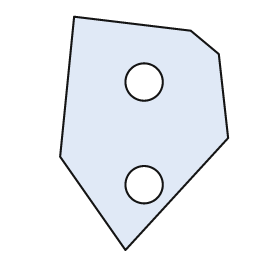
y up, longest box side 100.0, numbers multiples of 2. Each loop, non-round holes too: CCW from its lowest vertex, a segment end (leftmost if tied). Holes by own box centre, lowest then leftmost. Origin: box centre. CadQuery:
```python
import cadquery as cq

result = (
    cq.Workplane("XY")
    .moveTo(-8.0, -50.0)
    .lineTo(36.0, -2.0)
    .lineTo(32.0, 34.0)
    .lineTo(20.0, 44.0)
    .lineTo(-30.0, 50.0)
    .lineTo(-36.0, -10.0)
    .close()
    .moveTo(0.0, -22.0)
    .circle(8.0)
    .moveTo(0.0, 22.0)
    .circle(8.0)
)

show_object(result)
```